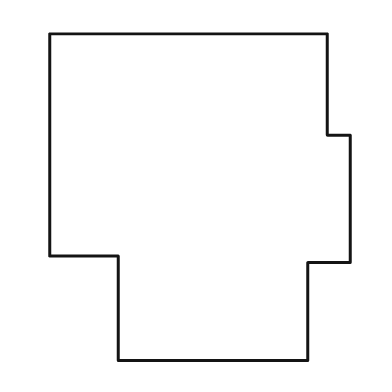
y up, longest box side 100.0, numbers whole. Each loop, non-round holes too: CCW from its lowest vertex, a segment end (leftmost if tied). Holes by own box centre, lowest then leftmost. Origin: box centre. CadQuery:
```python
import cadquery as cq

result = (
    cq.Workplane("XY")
    .moveTo(-25.0, -50.0)
    .lineTo(33.0, -50.0)
    .lineTo(33.0, -20.0)
    .lineTo(46.0, -20.0)
    .lineTo(46.0, 19.0)
    .lineTo(39.0, 19.0)
    .lineTo(39.0, 50.0)
    .lineTo(-46.0, 50.0)
    .lineTo(-46.0, -18.0)
    .lineTo(-25.0, -18.0)
    .close()
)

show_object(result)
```